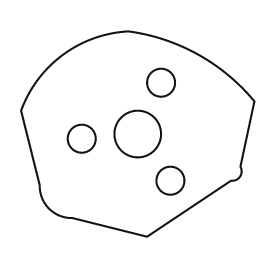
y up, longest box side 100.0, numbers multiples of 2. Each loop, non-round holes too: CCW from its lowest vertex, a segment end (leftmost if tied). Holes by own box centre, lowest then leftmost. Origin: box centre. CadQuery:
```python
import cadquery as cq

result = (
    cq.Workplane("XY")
    .moveTo(4.0, -44.0)
    .lineTo(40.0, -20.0)
    .threePointArc((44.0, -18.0), (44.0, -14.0))
    .lineTo(50.0, 14.0)
    .threePointArc((26.0, 34.0), (-4.0, 44.0))
    .threePointArc((-32.0, 34.0), (-50.0, 10.0))
    .lineTo(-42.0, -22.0)
    .threePointArc((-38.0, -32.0), (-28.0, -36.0))
    .close()
    .moveTo(14.0, -20.0)
    .circle(6.0)
    .moveTo(-24.0, -2.0)
    .circle(6.0)
    .moveTo(0.0, 0.0)
    .circle(10.0)
    .moveTo(10.0, 22.0)
    .circle(6.0)
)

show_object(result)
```